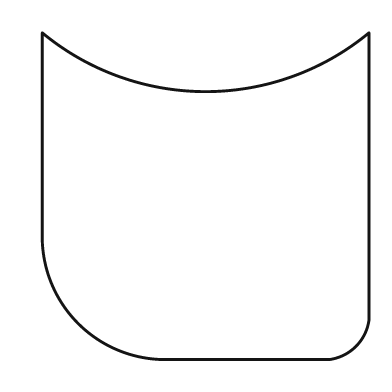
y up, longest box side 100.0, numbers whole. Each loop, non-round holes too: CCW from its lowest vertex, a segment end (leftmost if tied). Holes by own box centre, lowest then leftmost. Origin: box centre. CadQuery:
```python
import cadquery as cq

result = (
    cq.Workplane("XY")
    .moveTo(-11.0, -50.0)
    .lineTo(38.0, -50.0)
    .threePointArc((46.0, -46.0), (50.0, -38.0))
    .lineTo(50.0, 50.0)
    .threePointArc((0.0, 32.0), (-50.0, 50.0))
    .lineTo(-50.0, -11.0)
    .threePointArc((-39.0, -39.0), (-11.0, -50.0))
    .close()
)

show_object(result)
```